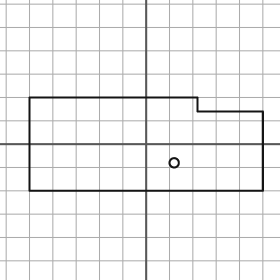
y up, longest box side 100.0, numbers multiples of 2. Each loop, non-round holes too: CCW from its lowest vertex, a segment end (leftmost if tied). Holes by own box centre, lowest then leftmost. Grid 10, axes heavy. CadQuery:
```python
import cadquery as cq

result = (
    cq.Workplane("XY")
    .moveTo(-50.0, -20.0)
    .lineTo(50.0, -20.0)
    .lineTo(50.0, 14.0)
    .lineTo(22.0, 14.0)
    .lineTo(22.0, 20.0)
    .lineTo(-50.0, 20.0)
    .close()
    .moveTo(12.0, -8.0)
    .circle(2.0)
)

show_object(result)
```